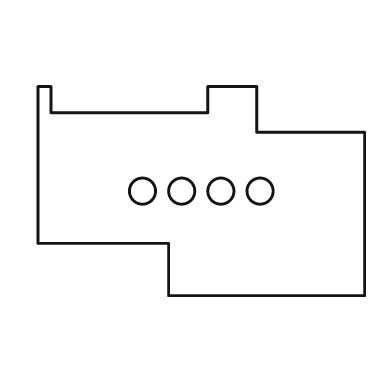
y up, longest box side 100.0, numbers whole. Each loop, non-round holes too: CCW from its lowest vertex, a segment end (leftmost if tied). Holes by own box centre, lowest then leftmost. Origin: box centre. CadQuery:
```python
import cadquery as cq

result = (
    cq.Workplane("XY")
    .moveTo(-10.0, -32.0)
    .lineTo(50.0, -32.0)
    .lineTo(50.0, 18.0)
    .lineTo(17.0, 18.0)
    .lineTo(17.0, 32.0)
    .lineTo(2.0, 32.0)
    .lineTo(2.0, 24.0)
    .lineTo(-46.0, 24.0)
    .lineTo(-46.0, 32.0)
    .lineTo(-50.0, 32.0)
    .lineTo(-50.0, -16.0)
    .lineTo(-10.0, -16.0)
    .close()
    .moveTo(-18.0, 0.0)
    .circle(4.0)
    .moveTo(-6.0, 0.0)
    .circle(4.0)
    .moveTo(6.0, 0.0)
    .circle(4.0)
    .moveTo(18.0, 0.0)
    .circle(4.0)
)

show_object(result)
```